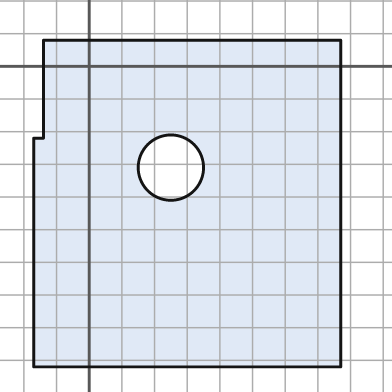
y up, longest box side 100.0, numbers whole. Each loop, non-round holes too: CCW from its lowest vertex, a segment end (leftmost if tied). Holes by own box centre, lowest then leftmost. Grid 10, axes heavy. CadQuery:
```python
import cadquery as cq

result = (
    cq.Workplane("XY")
    .moveTo(-17.0, -92.0)
    .lineTo(77.0, -92.0)
    .lineTo(77.0, 8.0)
    .lineTo(-14.0, 8.0)
    .lineTo(-14.0, -22.0)
    .lineTo(-17.0, -22.0)
    .close()
    .moveTo(25.0, -31.0)
    .circle(10.0)
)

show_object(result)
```